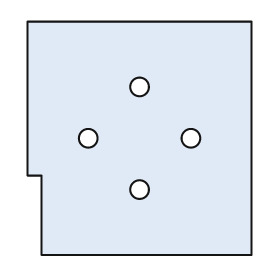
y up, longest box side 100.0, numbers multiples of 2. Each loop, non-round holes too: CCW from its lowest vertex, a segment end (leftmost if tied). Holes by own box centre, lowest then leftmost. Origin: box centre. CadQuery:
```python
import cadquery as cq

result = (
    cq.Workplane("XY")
    .moveTo(-42.0, -50.0)
    .lineTo(48.0, -50.0)
    .lineTo(48.0, 50.0)
    .lineTo(-48.0, 50.0)
    .lineTo(-48.0, -16.0)
    .lineTo(-42.0, -16.0)
    .close()
    .moveTo(0.0, -22.0)
    .circle(4.0)
    .moveTo(-22.0, 0.0)
    .circle(4.0)
    .moveTo(22.0, 0.0)
    .circle(4.0)
    .moveTo(0.0, 22.0)
    .circle(4.0)
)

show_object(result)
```